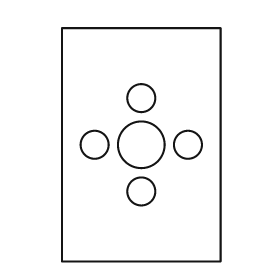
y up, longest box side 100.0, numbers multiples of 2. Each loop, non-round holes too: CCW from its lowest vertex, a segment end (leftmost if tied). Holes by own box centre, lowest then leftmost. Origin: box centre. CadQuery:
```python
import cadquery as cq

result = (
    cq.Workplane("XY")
    .moveTo(-34.0, -50.0)
    .lineTo(34.0, -50.0)
    .lineTo(34.0, 50.0)
    .lineTo(-34.0, 50.0)
    .close()
    .moveTo(0.0, -20.0)
    .circle(6.0)
    .moveTo(-20.0, 0.0)
    .circle(6.0)
    .moveTo(0.0, 0.0)
    .circle(10.0)
    .moveTo(20.0, 0.0)
    .circle(6.0)
    .moveTo(0.0, 20.0)
    .circle(6.0)
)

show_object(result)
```